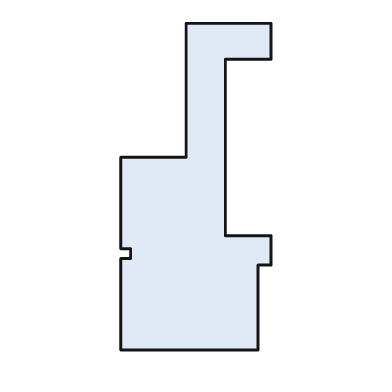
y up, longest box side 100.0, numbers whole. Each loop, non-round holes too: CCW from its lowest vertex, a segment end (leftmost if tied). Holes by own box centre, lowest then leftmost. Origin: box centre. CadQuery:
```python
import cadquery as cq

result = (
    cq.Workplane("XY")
    .moveTo(-23.0, -50.0)
    .lineTo(19.0, -50.0)
    .lineTo(19.0, -24.0)
    .lineTo(23.0, -24.0)
    .lineTo(23.0, -15.0)
    .lineTo(9.0, -15.0)
    .lineTo(9.0, 39.0)
    .lineTo(23.0, 39.0)
    .lineTo(23.0, 50.0)
    .lineTo(-3.0, 50.0)
    .lineTo(-3.0, 9.0)
    .lineTo(-23.0, 9.0)
    .lineTo(-23.0, -19.0)
    .lineTo(-20.0, -19.0)
    .lineTo(-20.0, -22.0)
    .lineTo(-23.0, -22.0)
    .close()
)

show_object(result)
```